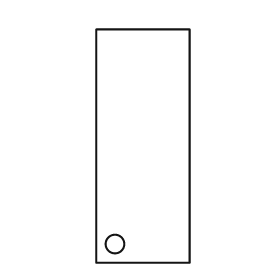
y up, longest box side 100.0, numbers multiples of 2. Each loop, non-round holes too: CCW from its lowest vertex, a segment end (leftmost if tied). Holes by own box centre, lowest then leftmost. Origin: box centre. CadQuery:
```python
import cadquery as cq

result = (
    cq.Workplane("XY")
    .moveTo(-20.0, -50.0)
    .lineTo(20.0, -50.0)
    .lineTo(20.0, 50.0)
    .lineTo(-20.0, 50.0)
    .close()
    .moveTo(-12.0, -42.0)
    .circle(4.0)
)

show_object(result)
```